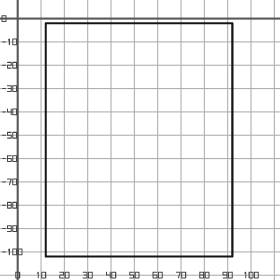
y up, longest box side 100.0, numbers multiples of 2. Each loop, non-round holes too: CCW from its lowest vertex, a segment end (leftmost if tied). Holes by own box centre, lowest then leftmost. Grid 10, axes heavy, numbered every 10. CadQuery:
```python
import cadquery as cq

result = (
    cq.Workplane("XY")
    .moveTo(12.0, -102.0)
    .lineTo(92.0, -102.0)
    .lineTo(92.0, -2.0)
    .lineTo(12.0, -2.0)
    .close()
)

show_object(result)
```